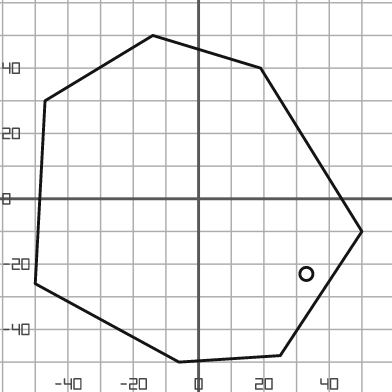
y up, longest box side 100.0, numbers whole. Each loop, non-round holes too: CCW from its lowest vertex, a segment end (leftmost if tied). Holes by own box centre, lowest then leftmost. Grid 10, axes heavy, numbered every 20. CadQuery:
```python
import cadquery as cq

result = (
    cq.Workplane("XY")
    .moveTo(-6.0, -50.0)
    .lineTo(25.0, -48.0)
    .lineTo(50.0, -10.0)
    .lineTo(19.0, 40.0)
    .lineTo(-14.0, 50.0)
    .lineTo(-47.0, 30.0)
    .lineTo(-50.0, -26.0)
    .close()
    .moveTo(33.0, -23.0)
    .circle(2.0)
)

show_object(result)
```